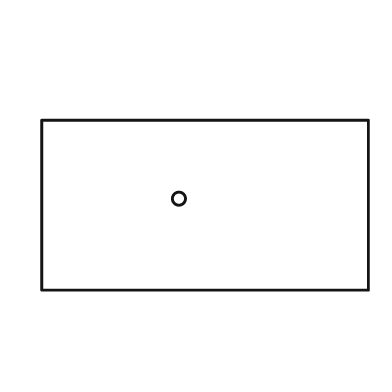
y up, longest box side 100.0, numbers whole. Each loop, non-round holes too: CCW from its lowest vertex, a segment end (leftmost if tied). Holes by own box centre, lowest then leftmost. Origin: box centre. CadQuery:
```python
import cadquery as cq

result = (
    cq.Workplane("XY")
    .moveTo(-50.0, -26.0)
    .lineTo(50.0, -26.0)
    .lineTo(50.0, 26.0)
    .lineTo(-50.0, 26.0)
    .close()
    .moveTo(-8.0, 2.0)
    .circle(2.0)
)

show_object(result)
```